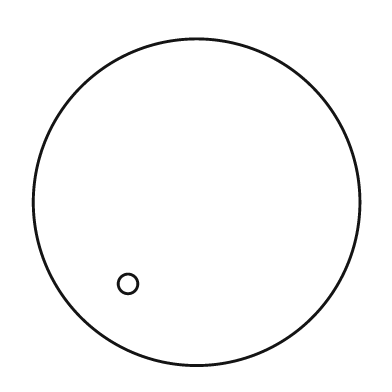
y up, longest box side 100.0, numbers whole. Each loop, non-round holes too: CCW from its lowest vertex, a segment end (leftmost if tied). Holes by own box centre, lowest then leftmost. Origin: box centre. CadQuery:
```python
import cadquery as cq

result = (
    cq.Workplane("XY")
    .moveTo(0.0, 0.0)
    .circle(50.0)
    .moveTo(-21.0, -25.0)
    .circle(3.0)
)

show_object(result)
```